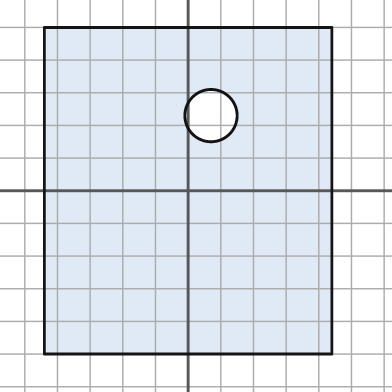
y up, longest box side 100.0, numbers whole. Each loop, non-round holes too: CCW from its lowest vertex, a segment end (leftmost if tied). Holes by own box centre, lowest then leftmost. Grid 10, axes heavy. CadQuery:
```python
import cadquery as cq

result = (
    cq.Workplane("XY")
    .moveTo(-44.0, -50.0)
    .lineTo(44.0, -50.0)
    .lineTo(44.0, 50.0)
    .lineTo(-44.0, 50.0)
    .close()
    .moveTo(7.0, 23.0)
    .circle(8.0)
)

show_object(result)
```